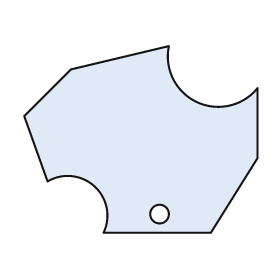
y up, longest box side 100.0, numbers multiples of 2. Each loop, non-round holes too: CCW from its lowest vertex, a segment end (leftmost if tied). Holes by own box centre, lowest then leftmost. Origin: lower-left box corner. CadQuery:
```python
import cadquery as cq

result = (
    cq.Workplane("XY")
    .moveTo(34.0, 0.0)
    .lineTo(80.0, 0.0)
    .lineTo(100.0, 32.0)
    .lineTo(100.0, 62.0)
    .threePointArc((74.0, 56.0), (62.0, 80.0))
    .lineTo(20.0, 70.0)
    .lineTo(0.0, 50.0)
    .lineTo(10.0, 22.0)
    .threePointArc((30.0, 20.0), (34.0, 0.0))
    .close()
    .moveTo(58.0, 8.0)
    .circle(4.0)
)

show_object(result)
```